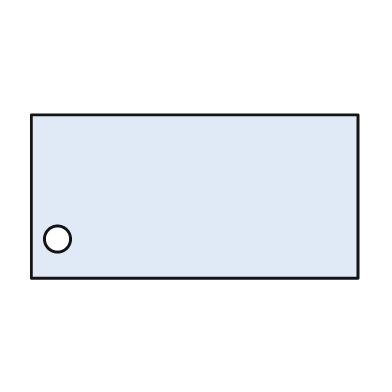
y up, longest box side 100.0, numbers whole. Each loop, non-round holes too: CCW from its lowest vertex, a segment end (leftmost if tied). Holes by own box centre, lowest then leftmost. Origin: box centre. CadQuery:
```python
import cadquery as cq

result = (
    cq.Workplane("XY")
    .moveTo(-50.0, -25.0)
    .lineTo(50.0, -25.0)
    .lineTo(50.0, 25.0)
    .lineTo(-50.0, 25.0)
    .close()
    .moveTo(-42.0, -13.0)
    .circle(4.0)
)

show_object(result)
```